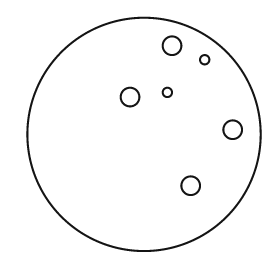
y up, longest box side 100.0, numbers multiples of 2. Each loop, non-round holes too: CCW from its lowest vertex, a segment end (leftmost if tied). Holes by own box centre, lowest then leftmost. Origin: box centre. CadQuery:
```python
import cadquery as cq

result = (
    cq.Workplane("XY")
    .moveTo(0.0, 0.0)
    .circle(50.0)
    .moveTo(20.0, -22.0)
    .circle(4.0)
    .moveTo(38.0, 2.0)
    .circle(4.0)
    .moveTo(-6.0, 16.0)
    .circle(4.0)
    .moveTo(10.0, 18.0)
    .circle(2.0)
    .moveTo(26.0, 32.0)
    .circle(2.0)
    .moveTo(12.0, 38.0)
    .circle(4.0)
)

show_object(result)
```